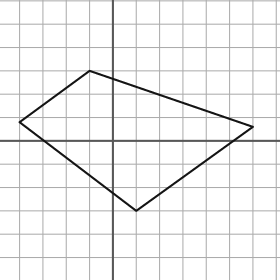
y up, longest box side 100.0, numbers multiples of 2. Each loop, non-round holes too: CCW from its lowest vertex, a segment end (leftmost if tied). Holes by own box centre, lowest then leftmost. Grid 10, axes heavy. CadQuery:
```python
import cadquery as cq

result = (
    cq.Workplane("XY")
    .moveTo(10.0, -30.0)
    .lineTo(60.0, 6.0)
    .lineTo(-10.0, 30.0)
    .lineTo(-40.0, 8.0)
    .close()
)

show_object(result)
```